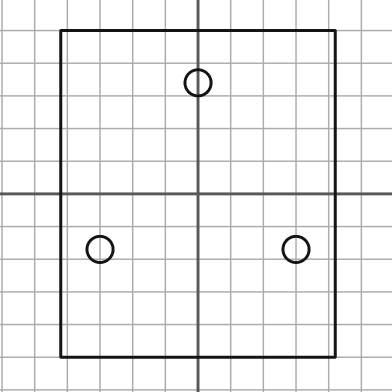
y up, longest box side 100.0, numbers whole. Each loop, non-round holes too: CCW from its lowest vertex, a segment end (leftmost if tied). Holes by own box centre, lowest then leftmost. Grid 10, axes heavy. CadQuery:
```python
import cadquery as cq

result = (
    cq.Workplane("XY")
    .moveTo(-42.0, -50.0)
    .lineTo(42.0, -50.0)
    .lineTo(42.0, 50.0)
    .lineTo(-42.0, 50.0)
    .close()
    .moveTo(-30.0, -17.0)
    .circle(4.0)
    .moveTo(30.0, -17.0)
    .circle(4.0)
    .moveTo(0.0, 34.0)
    .circle(4.0)
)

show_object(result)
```